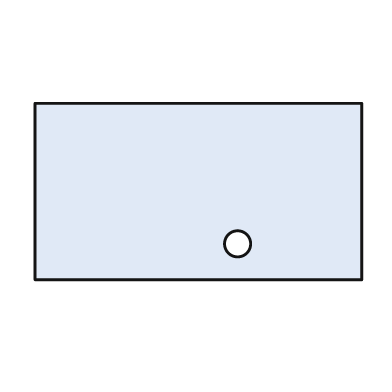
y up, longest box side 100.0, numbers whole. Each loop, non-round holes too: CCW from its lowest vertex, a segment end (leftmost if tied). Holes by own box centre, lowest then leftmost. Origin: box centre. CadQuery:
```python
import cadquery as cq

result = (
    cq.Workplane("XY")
    .moveTo(-50.0, -27.0)
    .lineTo(50.0, -27.0)
    .lineTo(50.0, 27.0)
    .lineTo(-50.0, 27.0)
    .close()
    .moveTo(12.0, -16.0)
    .circle(4.0)
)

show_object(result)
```